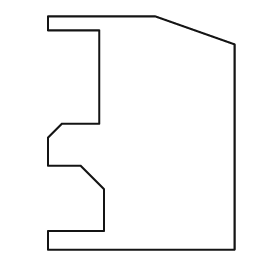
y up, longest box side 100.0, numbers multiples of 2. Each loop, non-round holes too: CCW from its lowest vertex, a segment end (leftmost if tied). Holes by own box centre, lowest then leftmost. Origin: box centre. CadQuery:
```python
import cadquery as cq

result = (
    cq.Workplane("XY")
    .moveTo(-40.0, -50.0)
    .lineTo(40.0, -50.0)
    .lineTo(40.0, 38.0)
    .lineTo(6.0, 50.0)
    .lineTo(-40.0, 50.0)
    .lineTo(-40.0, 44.0)
    .lineTo(-18.0, 44.0)
    .lineTo(-18.0, 4.0)
    .lineTo(-34.0, 4.0)
    .lineTo(-40.0, -2.0)
    .lineTo(-40.0, -14.0)
    .lineTo(-26.0, -14.0)
    .lineTo(-16.0, -24.0)
    .lineTo(-16.0, -42.0)
    .lineTo(-40.0, -42.0)
    .close()
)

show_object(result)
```